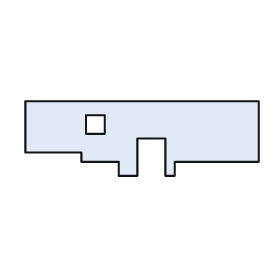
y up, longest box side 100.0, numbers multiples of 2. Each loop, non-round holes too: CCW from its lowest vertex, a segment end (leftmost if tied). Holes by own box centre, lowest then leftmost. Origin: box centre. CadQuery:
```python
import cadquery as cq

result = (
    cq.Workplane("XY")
    .moveTo(-10.0, -16.0)
    .lineTo(-2.0, -16.0)
    .lineTo(-2.0, 0.0)
    .lineTo(10.0, 0.0)
    .lineTo(10.0, -16.0)
    .lineTo(14.0, -16.0)
    .lineTo(14.0, -10.0)
    .lineTo(50.0, -10.0)
    .lineTo(50.0, 16.0)
    .lineTo(-50.0, 16.0)
    .lineTo(-50.0, -6.0)
    .lineTo(-26.0, -6.0)
    .lineTo(-26.0, -10.0)
    .lineTo(-10.0, -10.0)
    .close()
    .moveTo(-24.0, 2.0)
    .lineTo(-16.0, 2.0)
    .lineTo(-16.0, 10.0)
    .lineTo(-24.0, 10.0)
    .close()
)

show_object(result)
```